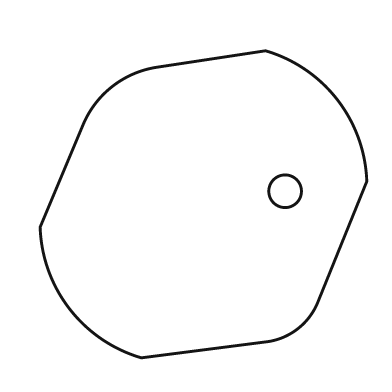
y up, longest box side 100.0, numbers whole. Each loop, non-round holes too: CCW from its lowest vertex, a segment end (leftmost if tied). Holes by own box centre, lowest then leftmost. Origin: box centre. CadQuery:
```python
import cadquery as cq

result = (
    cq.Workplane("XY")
    .moveTo(-19.0, -47.0)
    .lineTo(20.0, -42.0)
    .threePointArc((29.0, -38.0), (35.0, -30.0))
    .lineTo(50.0, 7.0)
    .threePointArc((41.0, 32.0), (19.0, 47.0))
    .lineTo(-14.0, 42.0)
    .threePointArc((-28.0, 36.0), (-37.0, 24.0))
    .lineTo(-50.0, -7.0)
    .threePointArc((-41.0, -32.0), (-19.0, -47.0))
    .close()
    .moveTo(25.0, 4.0)
    .circle(5.0)
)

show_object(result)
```